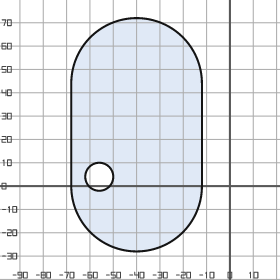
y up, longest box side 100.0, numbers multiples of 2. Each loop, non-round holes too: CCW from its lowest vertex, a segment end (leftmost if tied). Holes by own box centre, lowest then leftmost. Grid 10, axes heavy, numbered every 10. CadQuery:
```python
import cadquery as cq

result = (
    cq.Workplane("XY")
    .moveTo(-68.0, 0.0)
    .threePointArc((-40.0, -28.0), (-12.0, 0.0))
    .lineTo(-12.0, 44.0)
    .threePointArc((-40.0, 72.0), (-68.0, 44.0))
    .close()
    .moveTo(-56.0, 4.0)
    .circle(6.0)
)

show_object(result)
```